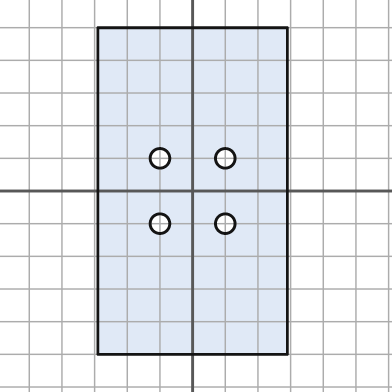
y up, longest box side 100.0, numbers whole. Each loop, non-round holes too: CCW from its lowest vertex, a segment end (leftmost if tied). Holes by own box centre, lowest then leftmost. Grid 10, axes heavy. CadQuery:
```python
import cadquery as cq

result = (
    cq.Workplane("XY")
    .moveTo(-29.0, -50.0)
    .lineTo(29.0, -50.0)
    .lineTo(29.0, 50.0)
    .lineTo(-29.0, 50.0)
    .close()
    .moveTo(-10.0, -10.0)
    .circle(3.0)
    .moveTo(10.0, -10.0)
    .circle(3.0)
    .moveTo(-10.0, 10.0)
    .circle(3.0)
    .moveTo(10.0, 10.0)
    .circle(3.0)
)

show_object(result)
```